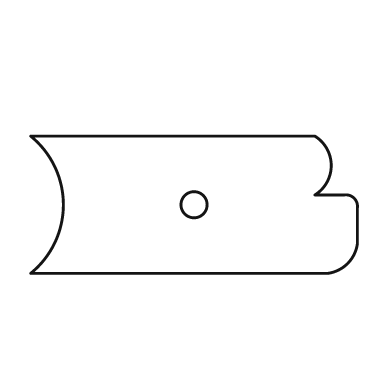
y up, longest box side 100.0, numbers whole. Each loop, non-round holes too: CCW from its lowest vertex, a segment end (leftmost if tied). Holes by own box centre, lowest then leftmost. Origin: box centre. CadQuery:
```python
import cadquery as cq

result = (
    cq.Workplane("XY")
    .moveTo(-50.0, -21.0)
    .lineTo(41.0, -21.0)
    .threePointArc((47.0, -18.0), (50.0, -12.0))
    .lineTo(50.0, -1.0)
    .threePointArc((49.0, 2.0), (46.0, 3.0))
    .lineTo(37.0, 3.0)
    .threePointArc((42.0, 12.0), (37.0, 21.0))
    .lineTo(-50.0, 21.0)
    .threePointArc((-40.0, 0.0), (-50.0, -21.0))
    .close()
    .moveTo(0.0, 0.0)
    .circle(4.0)
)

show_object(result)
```